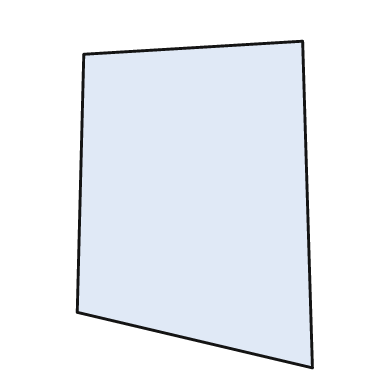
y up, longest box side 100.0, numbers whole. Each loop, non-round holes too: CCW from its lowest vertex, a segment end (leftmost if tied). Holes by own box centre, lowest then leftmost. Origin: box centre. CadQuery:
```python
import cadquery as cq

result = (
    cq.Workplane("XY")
    .moveTo(36.0, -50.0)
    .lineTo(33.0, 50.0)
    .lineTo(-34.0, 46.0)
    .lineTo(-36.0, -33.0)
    .close()
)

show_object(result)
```